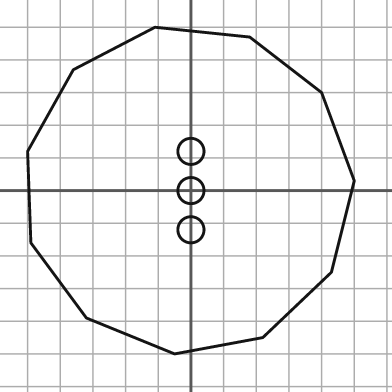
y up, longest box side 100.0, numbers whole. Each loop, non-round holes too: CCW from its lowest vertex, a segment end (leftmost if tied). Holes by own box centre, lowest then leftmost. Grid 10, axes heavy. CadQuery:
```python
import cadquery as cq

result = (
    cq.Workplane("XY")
    .moveTo(-5.0, -50.0)
    .lineTo(22.0, -45.0)
    .lineTo(43.0, -25.0)
    .lineTo(50.0, 3.0)
    .lineTo(40.0, 30.0)
    .lineTo(18.0, 47.0)
    .lineTo(-11.0, 50.0)
    .lineTo(-36.0, 37.0)
    .lineTo(-50.0, 12.0)
    .lineTo(-49.0, -16.0)
    .lineTo(-32.0, -39.0)
    .close()
    .moveTo(0.0, -12.0)
    .circle(4.0)
    .moveTo(0.0, 0.0)
    .circle(4.0)
    .moveTo(0.0, 12.0)
    .circle(4.0)
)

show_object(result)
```